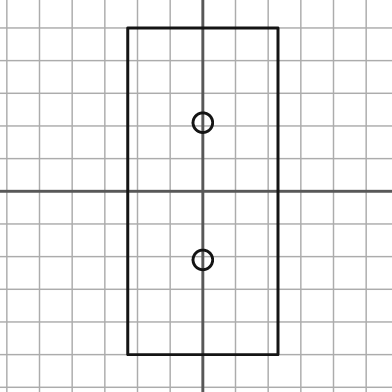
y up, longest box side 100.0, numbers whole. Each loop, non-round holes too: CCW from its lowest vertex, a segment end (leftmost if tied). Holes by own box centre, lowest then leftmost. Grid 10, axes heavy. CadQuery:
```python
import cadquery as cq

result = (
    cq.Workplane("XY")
    .moveTo(-23.0, -50.0)
    .lineTo(23.0, -50.0)
    .lineTo(23.0, 50.0)
    .lineTo(-23.0, 50.0)
    .close()
    .moveTo(0.0, -21.0)
    .circle(3.0)
    .moveTo(0.0, 21.0)
    .circle(3.0)
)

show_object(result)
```